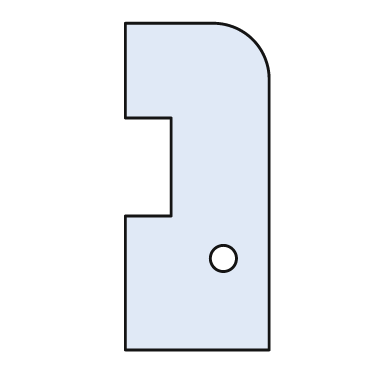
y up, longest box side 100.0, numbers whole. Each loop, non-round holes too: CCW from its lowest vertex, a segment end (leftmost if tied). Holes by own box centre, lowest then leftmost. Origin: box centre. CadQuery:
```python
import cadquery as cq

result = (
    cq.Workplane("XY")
    .moveTo(-22.0, -50.0)
    .lineTo(22.0, -50.0)
    .lineTo(22.0, 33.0)
    .threePointArc((17.0, 45.0), (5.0, 50.0))
    .lineTo(-22.0, 50.0)
    .lineTo(-22.0, 21.0)
    .lineTo(-8.0, 21.0)
    .lineTo(-8.0, -9.0)
    .lineTo(-22.0, -9.0)
    .close()
    .moveTo(8.0, -22.0)
    .circle(4.0)
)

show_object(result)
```